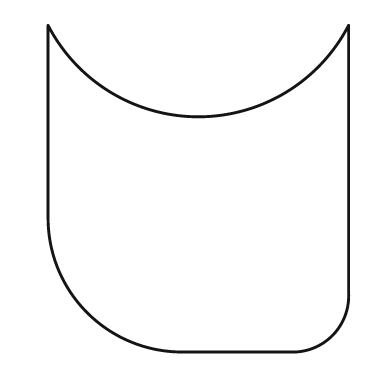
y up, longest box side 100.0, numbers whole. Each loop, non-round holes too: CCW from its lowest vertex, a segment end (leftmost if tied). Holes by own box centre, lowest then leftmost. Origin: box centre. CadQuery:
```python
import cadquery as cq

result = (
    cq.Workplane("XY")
    .moveTo(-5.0, -50.0)
    .lineTo(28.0, -50.0)
    .threePointArc((41.0, -45.0), (46.0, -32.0))
    .lineTo(46.0, 50.0)
    .threePointArc((0.0, 22.0), (-46.0, 50.0))
    .lineTo(-46.0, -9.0)
    .threePointArc((-34.0, -38.0), (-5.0, -50.0))
    .close()
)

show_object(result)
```